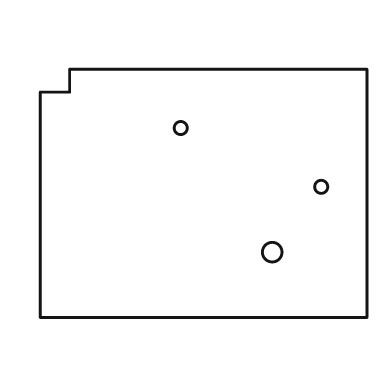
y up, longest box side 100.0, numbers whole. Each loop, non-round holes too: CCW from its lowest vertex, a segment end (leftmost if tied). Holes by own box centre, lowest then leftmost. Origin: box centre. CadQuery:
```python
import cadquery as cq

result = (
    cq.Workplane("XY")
    .moveTo(-50.0, -38.0)
    .lineTo(50.0, -38.0)
    .lineTo(50.0, 38.0)
    .lineTo(-41.0, 38.0)
    .lineTo(-41.0, 31.0)
    .lineTo(-50.0, 31.0)
    .close()
    .moveTo(21.0, -18.0)
    .circle(3.0)
    .moveTo(36.0, 2.0)
    .circle(2.0)
    .moveTo(-7.0, 20.0)
    .circle(2.0)
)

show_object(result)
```